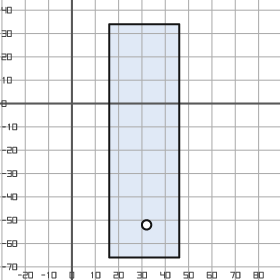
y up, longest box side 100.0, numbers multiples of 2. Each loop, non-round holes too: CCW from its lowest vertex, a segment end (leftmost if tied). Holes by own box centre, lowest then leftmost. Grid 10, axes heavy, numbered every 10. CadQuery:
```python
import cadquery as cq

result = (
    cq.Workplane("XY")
    .moveTo(16.0, -66.0)
    .lineTo(46.0, -66.0)
    .lineTo(46.0, 34.0)
    .lineTo(16.0, 34.0)
    .close()
    .moveTo(32.0, -52.0)
    .circle(2.0)
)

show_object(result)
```